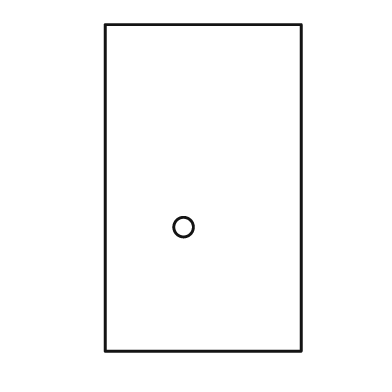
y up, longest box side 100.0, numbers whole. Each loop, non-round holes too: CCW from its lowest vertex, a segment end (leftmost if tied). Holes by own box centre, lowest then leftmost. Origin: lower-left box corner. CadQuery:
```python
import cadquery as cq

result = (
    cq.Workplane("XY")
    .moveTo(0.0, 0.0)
    .lineTo(60.0, 0.0)
    .lineTo(60.0, 100.0)
    .lineTo(0.0, 100.0)
    .close()
    .moveTo(24.0, 38.0)
    .circle(3.0)
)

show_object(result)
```